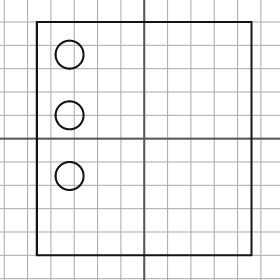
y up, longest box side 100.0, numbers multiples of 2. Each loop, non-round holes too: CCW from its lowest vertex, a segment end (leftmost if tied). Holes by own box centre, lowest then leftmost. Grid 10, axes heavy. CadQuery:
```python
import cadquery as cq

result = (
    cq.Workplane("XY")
    .moveTo(-46.0, -50.0)
    .lineTo(46.0, -50.0)
    .lineTo(46.0, 50.0)
    .lineTo(-46.0, 50.0)
    .close()
    .moveTo(-32.0, -16.0)
    .circle(6.0)
    .moveTo(-32.0, 10.0)
    .circle(6.0)
    .moveTo(-32.0, 36.0)
    .circle(6.0)
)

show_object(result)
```